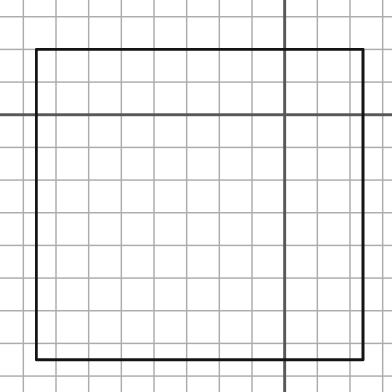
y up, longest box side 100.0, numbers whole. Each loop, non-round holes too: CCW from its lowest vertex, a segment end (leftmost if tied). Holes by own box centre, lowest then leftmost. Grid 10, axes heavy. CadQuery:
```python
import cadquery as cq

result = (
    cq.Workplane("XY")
    .moveTo(-76.0, -75.0)
    .lineTo(24.0, -75.0)
    .lineTo(24.0, 20.0)
    .lineTo(-76.0, 20.0)
    .close()
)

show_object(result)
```